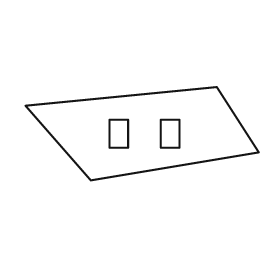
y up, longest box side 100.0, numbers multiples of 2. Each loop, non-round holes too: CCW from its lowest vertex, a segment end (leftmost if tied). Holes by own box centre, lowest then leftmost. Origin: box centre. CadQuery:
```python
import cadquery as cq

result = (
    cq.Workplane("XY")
    .moveTo(-22.0, -20.0)
    .lineTo(50.0, -8.0)
    .lineTo(32.0, 20.0)
    .lineTo(-50.0, 12.0)
    .close()
    .moveTo(-14.0, -6.0)
    .lineTo(-6.0, -6.0)
    .lineTo(-6.0, 6.0)
    .lineTo(-14.0, 6.0)
    .close()
    .moveTo(8.0, -6.0)
    .lineTo(16.0, -6.0)
    .lineTo(16.0, 6.0)
    .lineTo(8.0, 6.0)
    .close()
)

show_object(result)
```